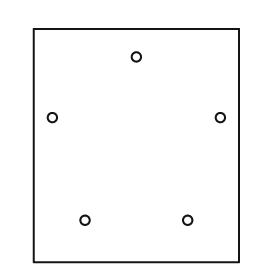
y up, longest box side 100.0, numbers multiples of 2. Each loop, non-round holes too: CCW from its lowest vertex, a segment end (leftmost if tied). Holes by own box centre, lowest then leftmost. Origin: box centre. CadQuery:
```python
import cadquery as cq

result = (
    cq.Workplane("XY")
    .moveTo(-44.0, -50.0)
    .lineTo(44.0, -50.0)
    .lineTo(44.0, 50.0)
    .lineTo(-44.0, 50.0)
    .close()
    .moveTo(-22.0, -32.0)
    .circle(2.0)
    .moveTo(22.0, -32.0)
    .circle(2.0)
    .moveTo(-36.0, 12.0)
    .circle(2.0)
    .moveTo(36.0, 12.0)
    .circle(2.0)
    .moveTo(0.0, 38.0)
    .circle(2.0)
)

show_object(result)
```